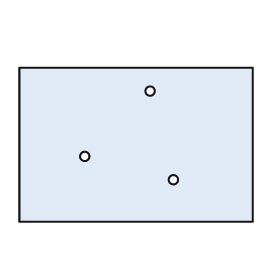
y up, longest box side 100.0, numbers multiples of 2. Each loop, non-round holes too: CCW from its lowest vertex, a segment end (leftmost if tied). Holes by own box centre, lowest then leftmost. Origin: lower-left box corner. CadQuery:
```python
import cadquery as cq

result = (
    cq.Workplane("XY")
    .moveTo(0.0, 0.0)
    .lineTo(100.0, 0.0)
    .lineTo(100.0, 66.0)
    .lineTo(0.0, 66.0)
    .close()
    .moveTo(66.0, 18.0)
    .circle(2.0)
    .moveTo(28.0, 28.0)
    .circle(2.0)
    .moveTo(56.0, 56.0)
    .circle(2.0)
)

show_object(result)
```